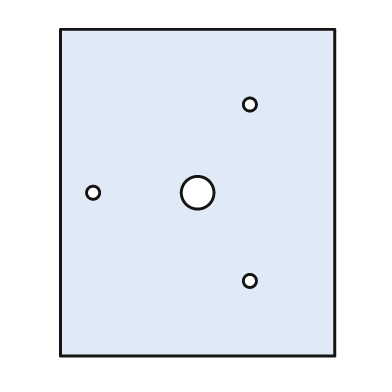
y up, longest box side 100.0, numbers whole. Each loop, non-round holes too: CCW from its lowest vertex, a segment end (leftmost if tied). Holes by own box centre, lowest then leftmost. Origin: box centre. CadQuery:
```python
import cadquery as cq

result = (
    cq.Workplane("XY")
    .moveTo(-42.0, -50.0)
    .lineTo(42.0, -50.0)
    .lineTo(42.0, 50.0)
    .lineTo(-42.0, 50.0)
    .close()
    .moveTo(16.0, -27.0)
    .circle(2.0)
    .moveTo(-32.0, 0.0)
    .circle(2.0)
    .moveTo(0.0, 0.0)
    .circle(5.0)
    .moveTo(16.0, 27.0)
    .circle(2.0)
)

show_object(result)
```